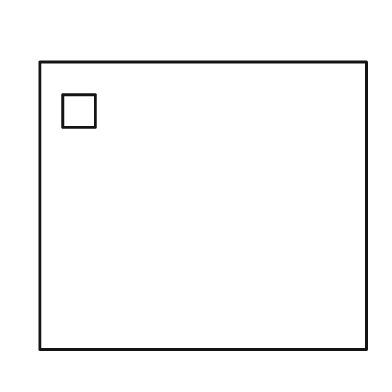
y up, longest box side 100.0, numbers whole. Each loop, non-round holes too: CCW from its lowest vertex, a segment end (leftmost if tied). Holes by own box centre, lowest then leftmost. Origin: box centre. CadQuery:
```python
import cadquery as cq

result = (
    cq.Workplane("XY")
    .moveTo(-50.0, -44.0)
    .lineTo(50.0, -44.0)
    .lineTo(50.0, 44.0)
    .lineTo(-50.0, 44.0)
    .close()
    .moveTo(-43.0, 24.0)
    .lineTo(-33.0, 24.0)
    .lineTo(-33.0, 34.0)
    .lineTo(-43.0, 34.0)
    .close()
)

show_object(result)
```